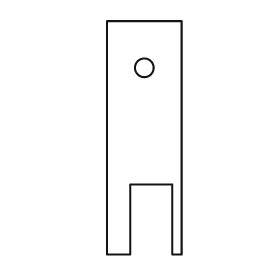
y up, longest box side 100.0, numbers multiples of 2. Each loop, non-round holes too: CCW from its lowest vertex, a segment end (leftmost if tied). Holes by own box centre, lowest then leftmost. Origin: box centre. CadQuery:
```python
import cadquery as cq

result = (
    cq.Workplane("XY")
    .moveTo(-16.0, -50.0)
    .lineTo(-6.0, -50.0)
    .lineTo(-6.0, -20.0)
    .lineTo(12.0, -20.0)
    .lineTo(12.0, -50.0)
    .lineTo(16.0, -50.0)
    .lineTo(16.0, 50.0)
    .lineTo(-16.0, 50.0)
    .close()
    .moveTo(0.0, 30.0)
    .circle(4.0)
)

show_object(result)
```